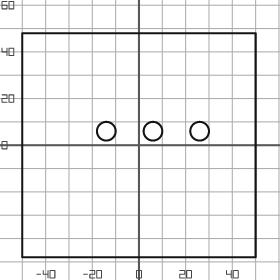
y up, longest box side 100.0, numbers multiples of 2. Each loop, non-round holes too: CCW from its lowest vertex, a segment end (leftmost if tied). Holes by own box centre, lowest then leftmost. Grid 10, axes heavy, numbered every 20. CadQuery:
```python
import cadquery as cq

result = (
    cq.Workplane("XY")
    .moveTo(-50.0, -48.0)
    .lineTo(50.0, -48.0)
    .lineTo(50.0, 48.0)
    .lineTo(-50.0, 48.0)
    .close()
    .moveTo(-14.0, 6.0)
    .circle(4.0)
    .moveTo(6.0, 6.0)
    .circle(4.0)
    .moveTo(26.0, 6.0)
    .circle(4.0)
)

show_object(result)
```